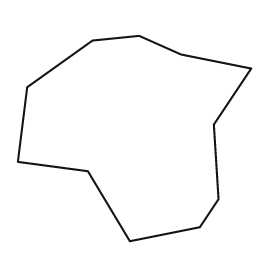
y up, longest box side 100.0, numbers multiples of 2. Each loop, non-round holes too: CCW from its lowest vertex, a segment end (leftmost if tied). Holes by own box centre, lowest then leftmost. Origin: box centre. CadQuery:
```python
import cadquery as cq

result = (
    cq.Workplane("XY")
    .moveTo(-2.0, -44.0)
    .lineTo(28.0, -38.0)
    .lineTo(36.0, -26.0)
    .lineTo(34.0, 6.0)
    .lineTo(50.0, 30.0)
    .lineTo(20.0, 36.0)
    .lineTo(2.0, 44.0)
    .lineTo(-18.0, 42.0)
    .lineTo(-46.0, 22.0)
    .lineTo(-50.0, -10.0)
    .lineTo(-20.0, -14.0)
    .close()
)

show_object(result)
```